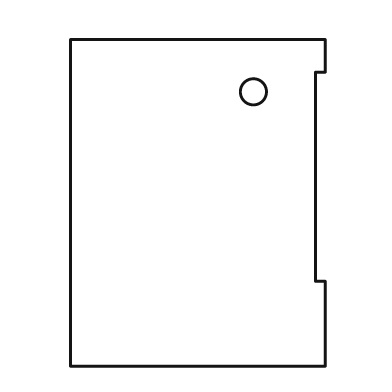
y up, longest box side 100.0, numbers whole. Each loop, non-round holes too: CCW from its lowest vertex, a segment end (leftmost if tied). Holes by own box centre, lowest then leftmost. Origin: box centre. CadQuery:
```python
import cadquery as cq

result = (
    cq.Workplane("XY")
    .moveTo(-39.0, -50.0)
    .lineTo(39.0, -50.0)
    .lineTo(39.0, -24.0)
    .lineTo(36.0, -24.0)
    .lineTo(36.0, 40.0)
    .lineTo(39.0, 40.0)
    .lineTo(39.0, 50.0)
    .lineTo(-39.0, 50.0)
    .close()
    .moveTo(17.0, 34.0)
    .circle(4.0)
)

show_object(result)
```